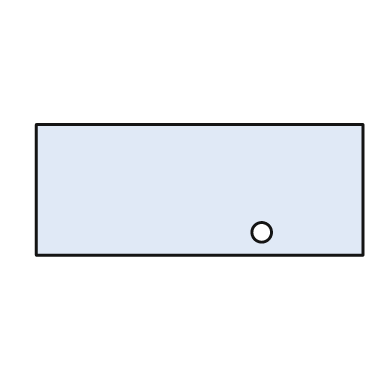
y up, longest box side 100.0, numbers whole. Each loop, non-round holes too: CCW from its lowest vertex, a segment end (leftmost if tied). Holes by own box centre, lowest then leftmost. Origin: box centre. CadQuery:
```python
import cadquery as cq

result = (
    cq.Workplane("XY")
    .moveTo(-50.0, -20.0)
    .lineTo(50.0, -20.0)
    .lineTo(50.0, 20.0)
    .lineTo(-50.0, 20.0)
    .close()
    .moveTo(19.0, -13.0)
    .circle(3.0)
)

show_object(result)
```